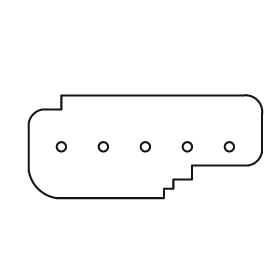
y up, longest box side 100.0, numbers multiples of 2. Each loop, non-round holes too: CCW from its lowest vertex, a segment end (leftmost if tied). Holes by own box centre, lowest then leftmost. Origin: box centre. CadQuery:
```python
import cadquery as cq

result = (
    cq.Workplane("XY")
    .moveTo(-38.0, -22.0)
    .lineTo(8.0, -22.0)
    .lineTo(8.0, -18.0)
    .lineTo(12.0, -18.0)
    .lineTo(12.0, -14.0)
    .lineTo(20.0, -14.0)
    .lineTo(20.0, -8.0)
    .lineTo(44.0, -8.0)
    .threePointArc((48.0, -6.0), (50.0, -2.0))
    .lineTo(50.0, 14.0)
    .threePointArc((48.0, 20.0), (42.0, 22.0))
    .lineTo(-36.0, 22.0)
    .lineTo(-36.0, 16.0)
    .lineTo(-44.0, 16.0)
    .threePointArc((-48.0, 14.0), (-50.0, 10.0))
    .lineTo(-50.0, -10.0)
    .threePointArc((-46.0, -18.0), (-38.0, -22.0))
    .close()
    .moveTo(-36.0, 0.0)
    .circle(2.0)
    .moveTo(-18.0, 0.0)
    .circle(2.0)
    .moveTo(0.0, 0.0)
    .circle(2.0)
    .moveTo(18.0, 0.0)
    .circle(2.0)
    .moveTo(36.0, 0.0)
    .circle(2.0)
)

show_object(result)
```